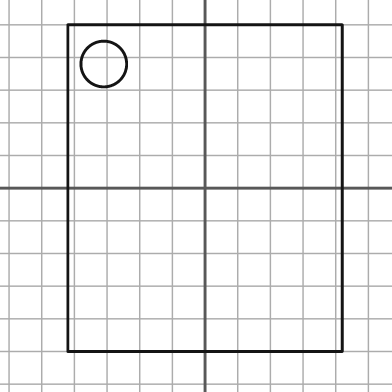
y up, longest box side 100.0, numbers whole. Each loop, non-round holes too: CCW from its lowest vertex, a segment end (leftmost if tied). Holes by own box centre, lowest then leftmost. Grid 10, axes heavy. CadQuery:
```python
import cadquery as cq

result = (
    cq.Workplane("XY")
    .moveTo(-42.0, -50.0)
    .lineTo(42.0, -50.0)
    .lineTo(42.0, 50.0)
    .lineTo(-42.0, 50.0)
    .close()
    .moveTo(-31.0, 38.0)
    .circle(7.0)
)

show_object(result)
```